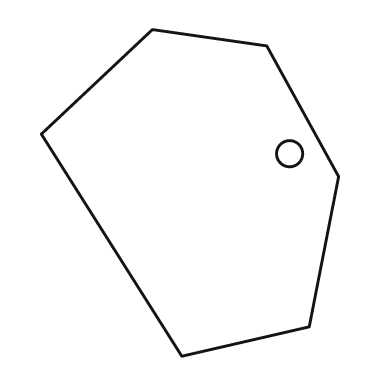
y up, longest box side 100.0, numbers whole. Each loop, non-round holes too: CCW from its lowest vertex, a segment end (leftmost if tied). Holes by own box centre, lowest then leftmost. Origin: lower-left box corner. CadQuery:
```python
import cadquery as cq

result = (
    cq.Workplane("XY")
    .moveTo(43.0, 0.0)
    .lineTo(82.0, 9.0)
    .lineTo(91.0, 55.0)
    .lineTo(69.0, 95.0)
    .lineTo(34.0, 100.0)
    .lineTo(0.0, 68.0)
    .close()
    .moveTo(76.0, 62.0)
    .circle(4.0)
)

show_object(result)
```